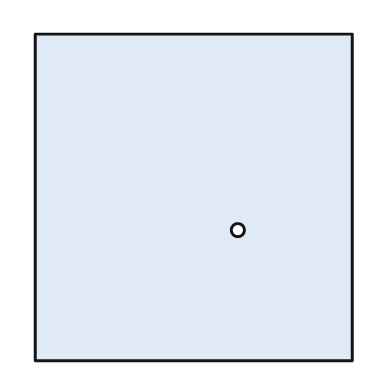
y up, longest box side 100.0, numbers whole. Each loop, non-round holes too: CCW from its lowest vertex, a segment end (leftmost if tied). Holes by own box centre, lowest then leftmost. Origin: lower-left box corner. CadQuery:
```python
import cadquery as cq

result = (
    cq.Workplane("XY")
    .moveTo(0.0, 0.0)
    .lineTo(97.0, 0.0)
    .lineTo(97.0, 100.0)
    .lineTo(0.0, 100.0)
    .close()
    .moveTo(62.0, 40.0)
    .circle(2.0)
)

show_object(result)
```